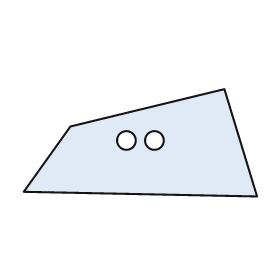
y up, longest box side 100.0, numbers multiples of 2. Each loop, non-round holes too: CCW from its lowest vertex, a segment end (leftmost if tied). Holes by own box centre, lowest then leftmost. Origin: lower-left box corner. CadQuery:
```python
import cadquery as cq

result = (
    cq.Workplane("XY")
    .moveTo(100.0, 0.0)
    .lineTo(86.0, 46.0)
    .lineTo(20.0, 30.0)
    .lineTo(0.0, 2.0)
    .close()
    .moveTo(44.0, 24.0)
    .circle(4.0)
    .moveTo(56.0, 24.0)
    .circle(4.0)
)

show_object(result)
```